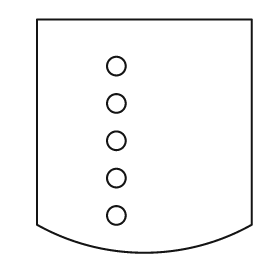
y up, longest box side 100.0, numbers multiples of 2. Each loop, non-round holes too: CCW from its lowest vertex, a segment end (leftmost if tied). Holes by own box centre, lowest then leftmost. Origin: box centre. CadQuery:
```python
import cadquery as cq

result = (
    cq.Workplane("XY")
    .moveTo(-46.0, -38.0)
    .threePointArc((0.0, -50.0), (46.0, -38.0))
    .lineTo(46.0, 50.0)
    .lineTo(-46.0, 50.0)
    .close()
    .moveTo(-12.0, -34.0)
    .circle(4.0)
    .moveTo(-12.0, -18.0)
    .circle(4.0)
    .moveTo(-12.0, -2.0)
    .circle(4.0)
    .moveTo(-12.0, 14.0)
    .circle(4.0)
    .moveTo(-12.0, 30.0)
    .circle(4.0)
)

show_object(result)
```